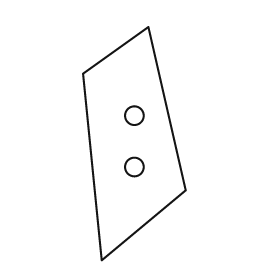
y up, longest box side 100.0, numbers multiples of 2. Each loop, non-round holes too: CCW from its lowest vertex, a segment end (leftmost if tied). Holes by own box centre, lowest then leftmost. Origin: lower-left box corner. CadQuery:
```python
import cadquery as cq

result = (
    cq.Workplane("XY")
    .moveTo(8.0, 0.0)
    .lineTo(44.0, 30.0)
    .lineTo(28.0, 100.0)
    .lineTo(0.0, 80.0)
    .close()
    .moveTo(22.0, 40.0)
    .circle(4.0)
    .moveTo(22.0, 62.0)
    .circle(4.0)
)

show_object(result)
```